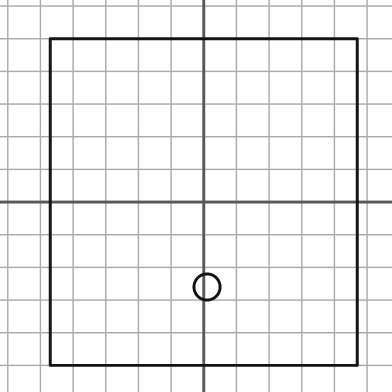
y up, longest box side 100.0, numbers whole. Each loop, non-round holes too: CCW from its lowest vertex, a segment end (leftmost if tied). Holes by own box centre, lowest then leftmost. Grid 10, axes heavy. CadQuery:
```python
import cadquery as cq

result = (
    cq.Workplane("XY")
    .moveTo(-47.0, -50.0)
    .lineTo(47.0, -50.0)
    .lineTo(47.0, 50.0)
    .lineTo(-47.0, 50.0)
    .close()
    .moveTo(1.0, -26.0)
    .circle(4.0)
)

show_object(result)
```